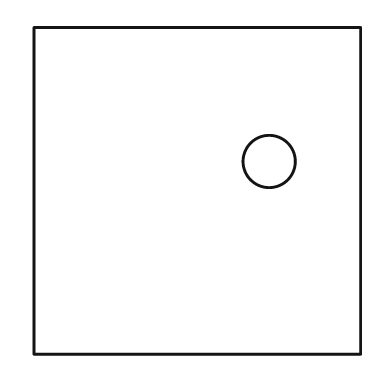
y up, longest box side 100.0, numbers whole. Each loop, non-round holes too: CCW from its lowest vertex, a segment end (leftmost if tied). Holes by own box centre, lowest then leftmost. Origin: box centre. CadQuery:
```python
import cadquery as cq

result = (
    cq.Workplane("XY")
    .moveTo(-50.0, -50.0)
    .lineTo(50.0, -50.0)
    .lineTo(50.0, 50.0)
    .lineTo(-50.0, 50.0)
    .close()
    .moveTo(22.0, 9.0)
    .circle(8.0)
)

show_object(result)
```